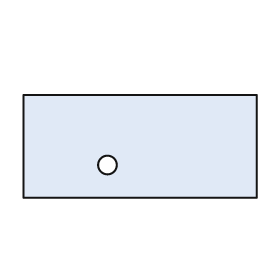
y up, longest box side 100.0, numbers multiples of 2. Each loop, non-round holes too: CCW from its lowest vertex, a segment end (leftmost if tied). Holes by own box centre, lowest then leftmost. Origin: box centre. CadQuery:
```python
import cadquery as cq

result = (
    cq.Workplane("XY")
    .moveTo(-50.0, -22.0)
    .lineTo(50.0, -22.0)
    .lineTo(50.0, 22.0)
    .lineTo(-50.0, 22.0)
    .close()
    .moveTo(-14.0, -8.0)
    .circle(4.0)
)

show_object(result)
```